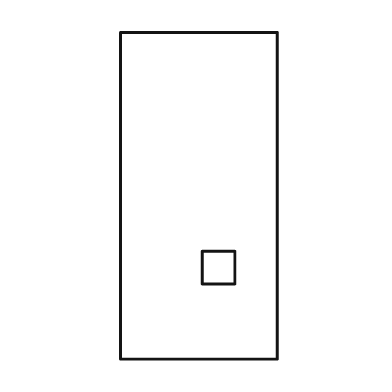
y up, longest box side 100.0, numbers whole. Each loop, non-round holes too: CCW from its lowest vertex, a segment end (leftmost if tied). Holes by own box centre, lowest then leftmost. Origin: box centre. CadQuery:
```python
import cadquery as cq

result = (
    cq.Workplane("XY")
    .moveTo(-24.0, -50.0)
    .lineTo(24.0, -50.0)
    .lineTo(24.0, 50.0)
    .lineTo(-24.0, 50.0)
    .close()
    .moveTo(1.0, -27.0)
    .lineTo(11.0, -27.0)
    .lineTo(11.0, -17.0)
    .lineTo(1.0, -17.0)
    .close()
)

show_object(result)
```